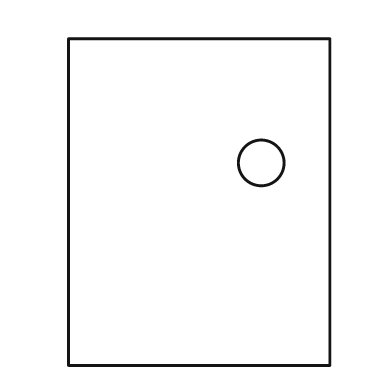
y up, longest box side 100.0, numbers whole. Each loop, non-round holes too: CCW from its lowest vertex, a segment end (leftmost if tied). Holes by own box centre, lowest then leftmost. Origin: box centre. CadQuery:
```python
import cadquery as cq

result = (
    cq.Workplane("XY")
    .moveTo(-40.0, -50.0)
    .lineTo(40.0, -50.0)
    .lineTo(40.0, 50.0)
    .lineTo(-40.0, 50.0)
    .close()
    .moveTo(19.0, 12.0)
    .circle(7.0)
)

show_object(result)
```